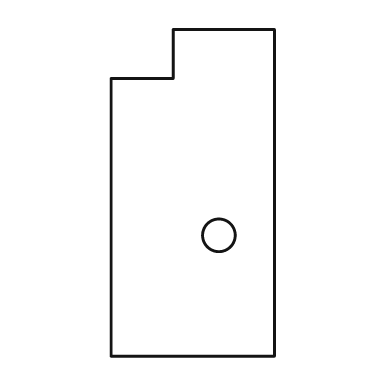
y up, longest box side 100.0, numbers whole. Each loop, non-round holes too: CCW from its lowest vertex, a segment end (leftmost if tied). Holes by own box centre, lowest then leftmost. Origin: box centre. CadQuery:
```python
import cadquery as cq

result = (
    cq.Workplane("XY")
    .moveTo(-25.0, -50.0)
    .lineTo(25.0, -50.0)
    .lineTo(25.0, 50.0)
    .lineTo(-6.0, 50.0)
    .lineTo(-6.0, 35.0)
    .lineTo(-25.0, 35.0)
    .close()
    .moveTo(8.0, -13.0)
    .circle(5.0)
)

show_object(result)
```